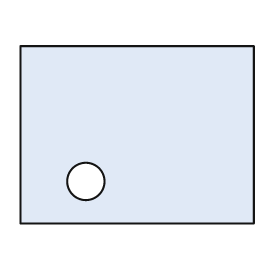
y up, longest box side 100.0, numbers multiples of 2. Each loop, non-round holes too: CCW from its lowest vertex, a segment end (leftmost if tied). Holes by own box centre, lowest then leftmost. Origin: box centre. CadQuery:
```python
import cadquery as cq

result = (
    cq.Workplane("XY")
    .moveTo(-50.0, -38.0)
    .lineTo(50.0, -38.0)
    .lineTo(50.0, 38.0)
    .lineTo(-50.0, 38.0)
    .close()
    .moveTo(-22.0, -20.0)
    .circle(8.0)
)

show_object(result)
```